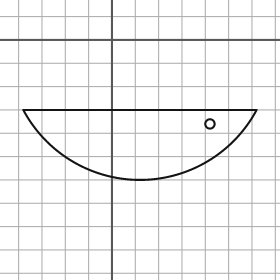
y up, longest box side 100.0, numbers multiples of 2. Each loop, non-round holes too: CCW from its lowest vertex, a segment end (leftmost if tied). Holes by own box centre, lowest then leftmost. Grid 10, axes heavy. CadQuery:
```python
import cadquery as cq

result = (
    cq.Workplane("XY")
    .moveTo(-38.0, -30.0)
    .threePointArc((12.0, -60.0), (62.0, -30.0))
    .close()
    .moveTo(42.0, -36.0)
    .circle(2.0)
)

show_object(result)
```